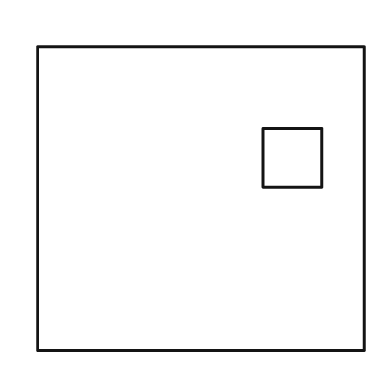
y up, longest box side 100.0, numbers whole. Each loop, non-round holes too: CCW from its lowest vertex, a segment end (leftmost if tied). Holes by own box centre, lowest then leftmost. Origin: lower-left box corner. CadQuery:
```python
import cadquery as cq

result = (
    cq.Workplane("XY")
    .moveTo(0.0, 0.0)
    .lineTo(100.0, 0.0)
    .lineTo(100.0, 93.0)
    .lineTo(0.0, 93.0)
    .close()
    .moveTo(69.0, 50.0)
    .lineTo(87.0, 50.0)
    .lineTo(87.0, 68.0)
    .lineTo(69.0, 68.0)
    .close()
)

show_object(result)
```